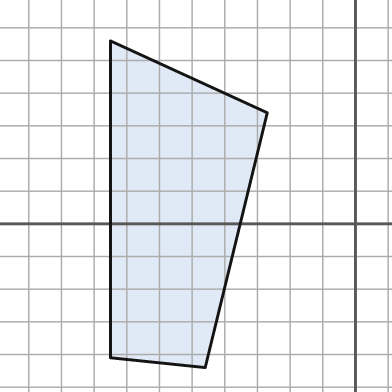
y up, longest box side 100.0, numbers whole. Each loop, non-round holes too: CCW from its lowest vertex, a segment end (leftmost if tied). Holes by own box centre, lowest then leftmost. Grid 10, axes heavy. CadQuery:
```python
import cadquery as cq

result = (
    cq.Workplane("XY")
    .moveTo(-46.0, -44.0)
    .lineTo(-27.0, 34.0)
    .lineTo(-75.0, 56.0)
    .lineTo(-75.0, -41.0)
    .close()
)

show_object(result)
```